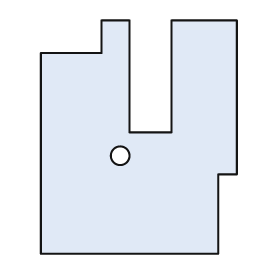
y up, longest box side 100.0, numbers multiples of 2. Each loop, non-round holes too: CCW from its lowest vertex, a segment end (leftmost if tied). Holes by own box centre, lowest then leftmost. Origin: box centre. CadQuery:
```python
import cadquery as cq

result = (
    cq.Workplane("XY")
    .moveTo(-42.0, -50.0)
    .lineTo(34.0, -50.0)
    .lineTo(34.0, -16.0)
    .lineTo(42.0, -16.0)
    .lineTo(42.0, 50.0)
    .lineTo(14.0, 50.0)
    .lineTo(14.0, 2.0)
    .lineTo(-4.0, 2.0)
    .lineTo(-4.0, 50.0)
    .lineTo(-16.0, 50.0)
    .lineTo(-16.0, 36.0)
    .lineTo(-42.0, 36.0)
    .close()
    .moveTo(-8.0, -8.0)
    .circle(4.0)
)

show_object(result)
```